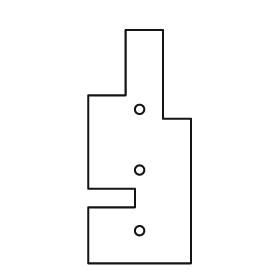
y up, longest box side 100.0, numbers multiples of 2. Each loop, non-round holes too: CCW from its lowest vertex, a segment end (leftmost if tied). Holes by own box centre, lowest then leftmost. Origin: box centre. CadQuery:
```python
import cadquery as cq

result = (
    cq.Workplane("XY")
    .moveTo(-22.0, -50.0)
    .lineTo(22.0, -50.0)
    .lineTo(22.0, 12.0)
    .lineTo(10.0, 12.0)
    .lineTo(10.0, 50.0)
    .lineTo(-6.0, 50.0)
    .lineTo(-6.0, 22.0)
    .lineTo(-22.0, 22.0)
    .lineTo(-22.0, -18.0)
    .lineTo(-2.0, -18.0)
    .lineTo(-2.0, -26.0)
    .lineTo(-22.0, -26.0)
    .close()
    .moveTo(0.0, -36.0)
    .circle(2.0)
    .moveTo(0.0, -10.0)
    .circle(2.0)
    .moveTo(0.0, 16.0)
    .circle(2.0)
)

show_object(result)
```